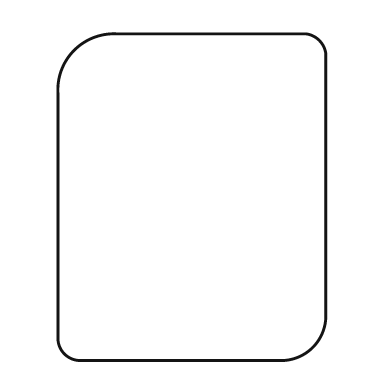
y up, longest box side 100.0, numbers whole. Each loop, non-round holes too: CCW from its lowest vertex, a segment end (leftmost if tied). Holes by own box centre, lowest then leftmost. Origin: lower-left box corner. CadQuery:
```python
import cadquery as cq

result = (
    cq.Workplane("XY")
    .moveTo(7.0, 0.0)
    .lineTo(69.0, 0.0)
    .threePointArc((78.0, 4.0), (82.0, 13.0))
    .lineTo(82.0, 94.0)
    .threePointArc((80.0, 98.0), (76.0, 100.0))
    .lineTo(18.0, 100.0)
    .threePointArc((5.0, 95.0), (0.0, 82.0))
    .lineTo(0.0, 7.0)
    .threePointArc((2.0, 2.0), (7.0, 0.0))
    .close()
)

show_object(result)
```